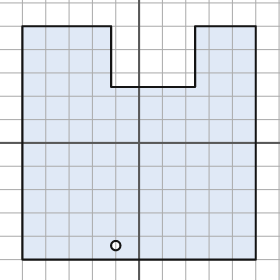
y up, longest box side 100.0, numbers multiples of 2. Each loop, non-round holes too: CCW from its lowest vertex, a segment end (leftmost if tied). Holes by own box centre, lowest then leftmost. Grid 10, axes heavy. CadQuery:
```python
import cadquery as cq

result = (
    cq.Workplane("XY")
    .moveTo(-50.0, -50.0)
    .lineTo(50.0, -50.0)
    .lineTo(50.0, 50.0)
    .lineTo(24.0, 50.0)
    .lineTo(24.0, 24.0)
    .lineTo(-12.0, 24.0)
    .lineTo(-12.0, 50.0)
    .lineTo(-50.0, 50.0)
    .close()
    .moveTo(-10.0, -44.0)
    .circle(2.0)
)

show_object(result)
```